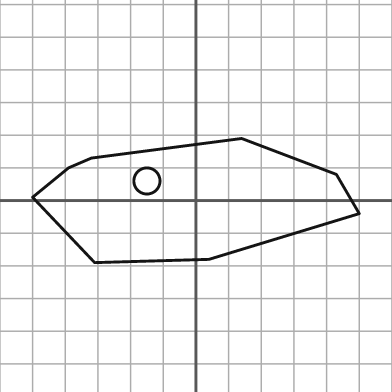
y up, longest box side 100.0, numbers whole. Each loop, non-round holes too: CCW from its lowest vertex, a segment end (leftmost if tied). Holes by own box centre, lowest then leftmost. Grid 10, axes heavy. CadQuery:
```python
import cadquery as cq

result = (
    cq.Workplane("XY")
    .moveTo(-31.0, -19.0)
    .lineTo(4.0, -18.0)
    .lineTo(50.0, -4.0)
    .lineTo(43.0, 8.0)
    .lineTo(14.0, 19.0)
    .lineTo(-32.0, 13.0)
    .lineTo(-39.0, 10.0)
    .lineTo(-50.0, 1.0)
    .close()
    .moveTo(-15.0, 6.0)
    .circle(4.0)
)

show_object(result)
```